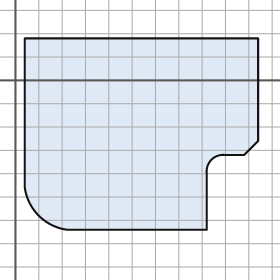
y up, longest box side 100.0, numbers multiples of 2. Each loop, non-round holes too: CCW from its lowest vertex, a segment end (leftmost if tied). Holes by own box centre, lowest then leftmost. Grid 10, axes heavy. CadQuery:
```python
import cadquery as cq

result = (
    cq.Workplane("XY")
    .moveTo(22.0, -64.0)
    .lineTo(82.0, -64.0)
    .lineTo(82.0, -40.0)
    .threePointArc((84.0, -34.0), (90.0, -32.0))
    .lineTo(98.0, -32.0)
    .lineTo(104.0, -26.0)
    .lineTo(104.0, 18.0)
    .lineTo(4.0, 18.0)
    .lineTo(4.0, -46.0)
    .threePointArc((10.0, -58.0), (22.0, -64.0))
    .close()
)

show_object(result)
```